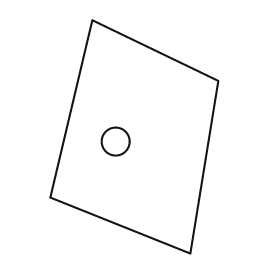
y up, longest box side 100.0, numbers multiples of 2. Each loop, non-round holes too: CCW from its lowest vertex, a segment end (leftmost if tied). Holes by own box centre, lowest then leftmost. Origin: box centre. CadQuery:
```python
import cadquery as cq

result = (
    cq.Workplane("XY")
    .moveTo(24.0, -50.0)
    .lineTo(36.0, 24.0)
    .lineTo(-18.0, 50.0)
    .lineTo(-36.0, -26.0)
    .close()
    .moveTo(-8.0, -2.0)
    .circle(6.0)
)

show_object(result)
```